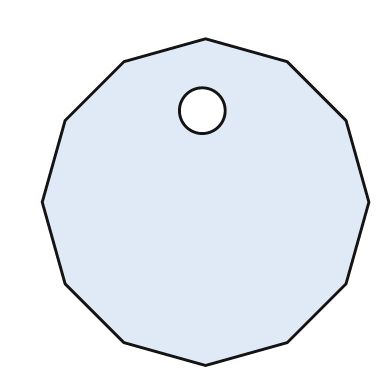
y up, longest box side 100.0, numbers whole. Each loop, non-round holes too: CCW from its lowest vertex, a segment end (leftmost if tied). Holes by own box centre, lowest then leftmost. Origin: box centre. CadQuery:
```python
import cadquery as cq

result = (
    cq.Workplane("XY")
    .moveTo(0.0, -50.0)
    .lineTo(25.0, -43.0)
    .lineTo(43.0, -25.0)
    .lineTo(50.0, 0.0)
    .lineTo(43.0, 25.0)
    .lineTo(25.0, 43.0)
    .lineTo(0.0, 50.0)
    .lineTo(-25.0, 43.0)
    .lineTo(-43.0, 25.0)
    .lineTo(-50.0, 0.0)
    .lineTo(-43.0, -25.0)
    .lineTo(-25.0, -43.0)
    .close()
    .moveTo(-1.0, 28.0)
    .circle(7.0)
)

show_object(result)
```